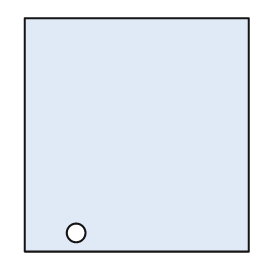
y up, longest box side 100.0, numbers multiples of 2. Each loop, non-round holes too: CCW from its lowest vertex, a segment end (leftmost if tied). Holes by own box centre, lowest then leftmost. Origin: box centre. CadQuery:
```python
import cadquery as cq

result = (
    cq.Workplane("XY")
    .moveTo(-48.0, -50.0)
    .lineTo(48.0, -50.0)
    .lineTo(48.0, 50.0)
    .lineTo(-48.0, 50.0)
    .close()
    .moveTo(-26.0, -42.0)
    .circle(4.0)
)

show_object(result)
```